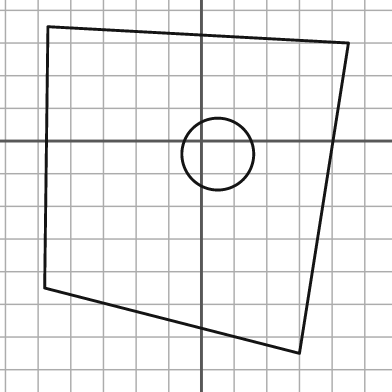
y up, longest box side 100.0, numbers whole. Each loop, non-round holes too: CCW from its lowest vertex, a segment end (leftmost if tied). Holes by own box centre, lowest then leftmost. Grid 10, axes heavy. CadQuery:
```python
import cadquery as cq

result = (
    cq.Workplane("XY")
    .moveTo(30.0, -65.0)
    .lineTo(45.0, 30.0)
    .lineTo(-47.0, 35.0)
    .lineTo(-48.0, -45.0)
    .close()
    .moveTo(5.0, -4.0)
    .circle(11.0)
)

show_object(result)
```